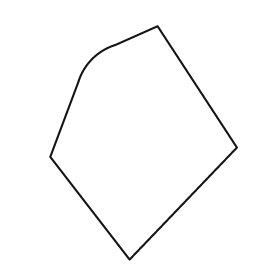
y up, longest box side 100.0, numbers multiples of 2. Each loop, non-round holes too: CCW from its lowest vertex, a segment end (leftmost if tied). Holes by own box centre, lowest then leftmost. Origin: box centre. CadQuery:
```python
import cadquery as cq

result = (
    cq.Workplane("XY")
    .moveTo(-6.0, -50.0)
    .lineTo(40.0, -2.0)
    .lineTo(6.0, 50.0)
    .lineTo(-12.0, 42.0)
    .threePointArc((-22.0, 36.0), (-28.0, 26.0))
    .lineTo(-40.0, -6.0)
    .close()
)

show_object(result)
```